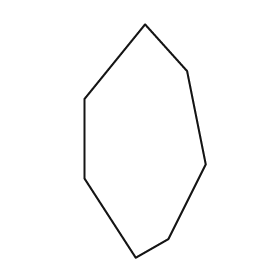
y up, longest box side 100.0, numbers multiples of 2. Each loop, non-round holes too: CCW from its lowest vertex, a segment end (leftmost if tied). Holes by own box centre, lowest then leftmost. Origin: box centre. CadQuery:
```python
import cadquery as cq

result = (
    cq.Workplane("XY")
    .moveTo(-4.0, -50.0)
    .lineTo(10.0, -42.0)
    .lineTo(26.0, -10.0)
    .lineTo(18.0, 30.0)
    .lineTo(0.0, 50.0)
    .lineTo(-26.0, 18.0)
    .lineTo(-26.0, -16.0)
    .close()
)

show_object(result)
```